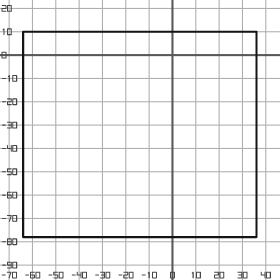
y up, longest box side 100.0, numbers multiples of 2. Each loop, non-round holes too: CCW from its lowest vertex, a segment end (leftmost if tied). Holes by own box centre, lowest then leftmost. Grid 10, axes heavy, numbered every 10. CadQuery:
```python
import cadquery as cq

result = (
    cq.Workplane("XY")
    .moveTo(-64.0, -78.0)
    .lineTo(36.0, -78.0)
    .lineTo(36.0, 10.0)
    .lineTo(-64.0, 10.0)
    .close()
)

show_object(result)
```